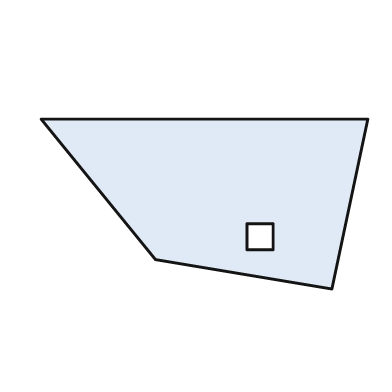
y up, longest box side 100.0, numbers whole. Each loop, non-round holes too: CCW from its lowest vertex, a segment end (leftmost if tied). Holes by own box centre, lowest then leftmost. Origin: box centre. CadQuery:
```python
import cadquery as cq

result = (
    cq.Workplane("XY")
    .moveTo(39.0, -26.0)
    .lineTo(50.0, 26.0)
    .lineTo(-50.0, 26.0)
    .lineTo(-15.0, -17.0)
    .close()
    .moveTo(13.0, -14.0)
    .lineTo(21.0, -14.0)
    .lineTo(21.0, -6.0)
    .lineTo(13.0, -6.0)
    .close()
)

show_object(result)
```